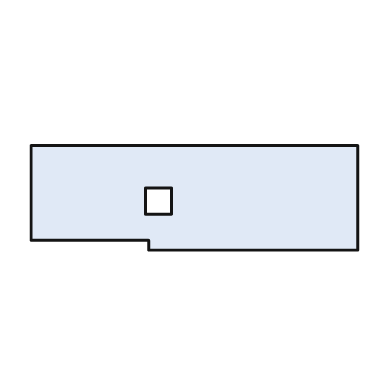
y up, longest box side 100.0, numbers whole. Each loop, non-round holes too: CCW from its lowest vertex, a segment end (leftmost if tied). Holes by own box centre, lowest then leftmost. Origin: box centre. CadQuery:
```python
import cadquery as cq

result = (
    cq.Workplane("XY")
    .moveTo(-14.0, -16.0)
    .lineTo(50.0, -16.0)
    .lineTo(50.0, 16.0)
    .lineTo(-50.0, 16.0)
    .lineTo(-50.0, -13.0)
    .lineTo(-14.0, -13.0)
    .close()
    .moveTo(-15.0, -5.0)
    .lineTo(-7.0, -5.0)
    .lineTo(-7.0, 3.0)
    .lineTo(-15.0, 3.0)
    .close()
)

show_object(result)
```